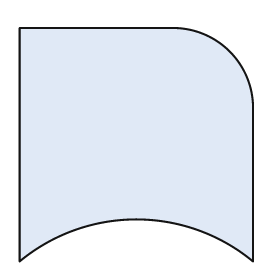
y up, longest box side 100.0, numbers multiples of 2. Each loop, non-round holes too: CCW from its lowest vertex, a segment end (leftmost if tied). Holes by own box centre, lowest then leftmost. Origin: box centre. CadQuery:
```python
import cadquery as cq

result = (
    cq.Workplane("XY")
    .moveTo(-50.0, -50.0)
    .threePointArc((0.0, -32.0), (50.0, -50.0))
    .lineTo(50.0, 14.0)
    .threePointArc((40.0, 40.0), (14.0, 50.0))
    .lineTo(-50.0, 50.0)
    .close()
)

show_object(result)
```